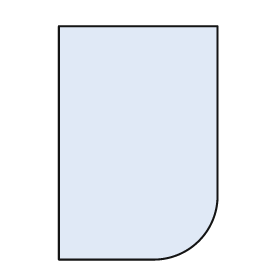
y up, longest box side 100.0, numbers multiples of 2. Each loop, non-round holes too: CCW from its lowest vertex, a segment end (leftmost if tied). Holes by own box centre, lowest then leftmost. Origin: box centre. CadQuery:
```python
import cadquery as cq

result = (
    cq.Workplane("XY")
    .moveTo(-34.0, -50.0)
    .lineTo(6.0, -50.0)
    .threePointArc((26.0, -42.0), (34.0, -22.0))
    .lineTo(34.0, 50.0)
    .lineTo(-34.0, 50.0)
    .close()
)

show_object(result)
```